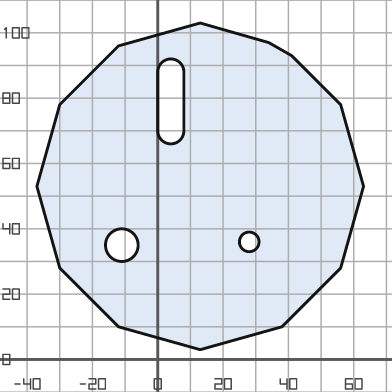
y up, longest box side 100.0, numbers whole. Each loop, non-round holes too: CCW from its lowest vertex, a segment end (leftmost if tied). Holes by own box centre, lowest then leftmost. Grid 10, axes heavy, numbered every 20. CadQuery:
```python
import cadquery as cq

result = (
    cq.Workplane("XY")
    .moveTo(13.0, 3.0)
    .lineTo(38.0, 10.0)
    .lineTo(56.0, 28.0)
    .lineTo(63.0, 53.0)
    .lineTo(56.0, 78.0)
    .lineTo(41.0, 93.0)
    .lineTo(34.0, 97.0)
    .lineTo(13.0, 103.0)
    .lineTo(-12.0, 96.0)
    .lineTo(-30.0, 78.0)
    .lineTo(-37.0, 53.0)
    .lineTo(-30.0, 28.0)
    .lineTo(-12.0, 10.0)
    .close()
    .moveTo(-11.0, 35.0)
    .circle(5.0)
    .moveTo(28.0, 36.0)
    .circle(3.0)
    .moveTo(0.0, 70.0)
    .threePointArc((4.0, 66.0), (8.0, 70.0))
    .lineTo(8.0, 88.0)
    .threePointArc((4.0, 92.0), (0.0, 88.0))
    .close()
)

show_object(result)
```